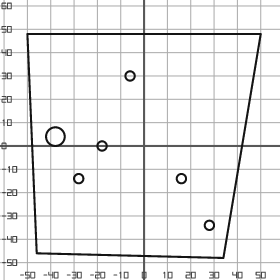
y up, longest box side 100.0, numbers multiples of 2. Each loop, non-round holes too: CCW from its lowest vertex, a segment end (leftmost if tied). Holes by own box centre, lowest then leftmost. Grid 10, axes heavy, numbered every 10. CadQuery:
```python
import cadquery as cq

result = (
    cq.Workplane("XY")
    .moveTo(34.0, -48.0)
    .lineTo(50.0, 48.0)
    .lineTo(-50.0, 48.0)
    .lineTo(-46.0, -46.0)
    .close()
    .moveTo(28.0, -34.0)
    .circle(2.0)
    .moveTo(-28.0, -14.0)
    .circle(2.0)
    .moveTo(16.0, -14.0)
    .circle(2.0)
    .moveTo(-18.0, 0.0)
    .circle(2.0)
    .moveTo(-38.0, 4.0)
    .circle(4.0)
    .moveTo(-6.0, 30.0)
    .circle(2.0)
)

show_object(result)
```